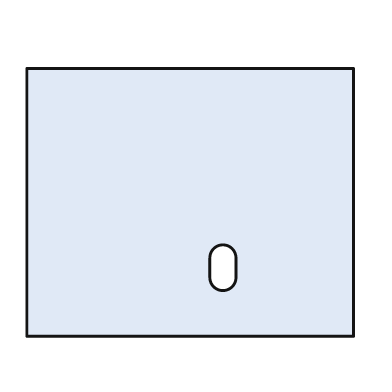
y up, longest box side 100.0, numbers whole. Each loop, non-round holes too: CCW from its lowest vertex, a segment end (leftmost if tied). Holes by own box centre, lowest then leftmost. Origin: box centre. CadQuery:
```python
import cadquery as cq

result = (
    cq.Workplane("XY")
    .moveTo(-50.0, -41.0)
    .lineTo(50.0, -41.0)
    .lineTo(50.0, 41.0)
    .lineTo(-50.0, 41.0)
    .close()
    .moveTo(6.0, -23.0)
    .threePointArc((10.0, -27.0), (14.0, -23.0))
    .lineTo(14.0, -17.0)
    .threePointArc((10.0, -13.0), (6.0, -17.0))
    .close()
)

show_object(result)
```